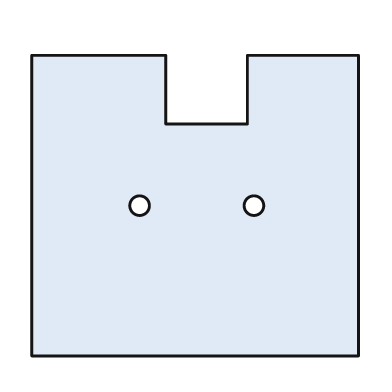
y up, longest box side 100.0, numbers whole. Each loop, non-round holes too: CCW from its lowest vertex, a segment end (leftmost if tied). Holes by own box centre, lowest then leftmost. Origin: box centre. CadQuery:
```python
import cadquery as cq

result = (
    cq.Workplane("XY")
    .moveTo(-50.0, -46.0)
    .lineTo(50.0, -46.0)
    .lineTo(50.0, 46.0)
    .lineTo(16.0, 46.0)
    .lineTo(16.0, 25.0)
    .lineTo(-9.0, 25.0)
    .lineTo(-9.0, 46.0)
    .lineTo(-50.0, 46.0)
    .close()
    .moveTo(-17.0, 0.0)
    .circle(3.0)
    .moveTo(18.0, 0.0)
    .circle(3.0)
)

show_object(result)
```